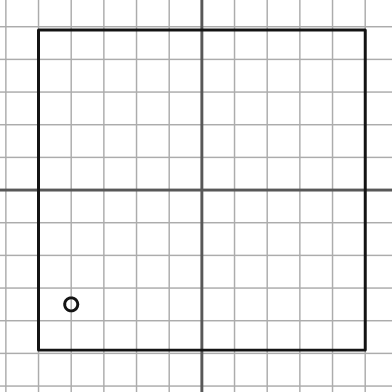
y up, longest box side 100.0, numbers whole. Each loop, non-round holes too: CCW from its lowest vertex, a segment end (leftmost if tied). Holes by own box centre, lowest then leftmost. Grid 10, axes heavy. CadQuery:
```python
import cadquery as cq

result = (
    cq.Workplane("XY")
    .moveTo(-50.0, -49.0)
    .lineTo(50.0, -49.0)
    .lineTo(50.0, 49.0)
    .lineTo(-50.0, 49.0)
    .close()
    .moveTo(-40.0, -35.0)
    .circle(2.0)
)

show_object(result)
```